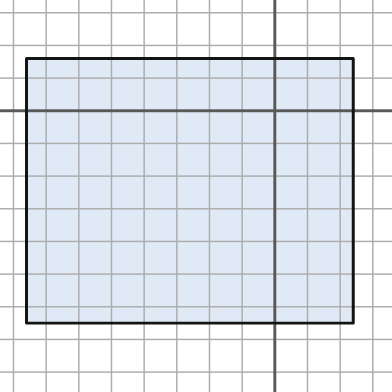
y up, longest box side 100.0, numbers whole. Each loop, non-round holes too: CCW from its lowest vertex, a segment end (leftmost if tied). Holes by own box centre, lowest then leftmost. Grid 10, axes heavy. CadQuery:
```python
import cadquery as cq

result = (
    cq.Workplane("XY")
    .moveTo(-76.0, -65.0)
    .lineTo(24.0, -65.0)
    .lineTo(24.0, 16.0)
    .lineTo(-76.0, 16.0)
    .close()
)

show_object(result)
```